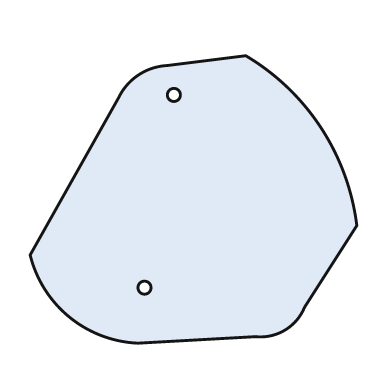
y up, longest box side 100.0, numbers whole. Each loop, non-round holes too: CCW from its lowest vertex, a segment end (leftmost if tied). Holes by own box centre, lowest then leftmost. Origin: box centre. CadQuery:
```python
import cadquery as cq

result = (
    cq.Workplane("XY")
    .moveTo(-17.0, -44.0)
    .lineTo(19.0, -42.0)
    .threePointArc((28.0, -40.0), (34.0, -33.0))
    .lineTo(50.0, -8.0)
    .threePointArc((39.0, 22.0), (16.0, 44.0))
    .lineTo(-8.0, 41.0)
    .threePointArc((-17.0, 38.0), (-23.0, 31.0))
    .lineTo(-50.0, -17.0)
    .threePointArc((-38.0, -36.0), (-17.0, -44.0))
    .close()
    .moveTo(-15.0, -27.0)
    .circle(2.0)
    .moveTo(-6.0, 32.0)
    .circle(2.0)
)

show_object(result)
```